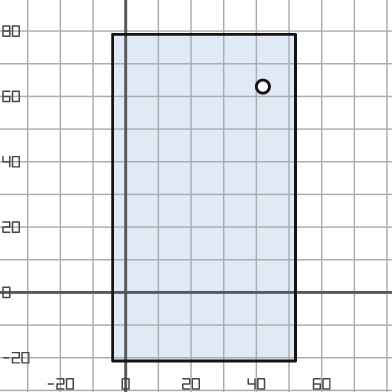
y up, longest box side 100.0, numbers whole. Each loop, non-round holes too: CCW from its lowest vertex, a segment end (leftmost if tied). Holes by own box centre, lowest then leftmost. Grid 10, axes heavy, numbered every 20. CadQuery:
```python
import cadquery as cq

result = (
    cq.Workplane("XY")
    .moveTo(-4.0, -21.0)
    .lineTo(52.0, -21.0)
    .lineTo(52.0, 79.0)
    .lineTo(-4.0, 79.0)
    .close()
    .moveTo(42.0, 63.0)
    .circle(2.0)
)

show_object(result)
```